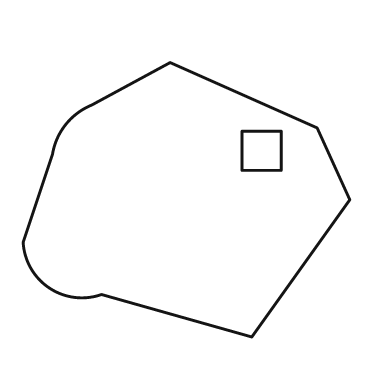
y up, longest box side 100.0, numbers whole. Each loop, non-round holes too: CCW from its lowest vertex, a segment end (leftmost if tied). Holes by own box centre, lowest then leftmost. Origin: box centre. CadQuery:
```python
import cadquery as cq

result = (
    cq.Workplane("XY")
    .moveTo(20.0, -42.0)
    .lineTo(50.0, 0.0)
    .lineTo(40.0, 22.0)
    .lineTo(-5.0, 42.0)
    .lineTo(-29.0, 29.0)
    .threePointArc((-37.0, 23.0), (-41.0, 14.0))
    .lineTo(-50.0, -13.0)
    .threePointArc((-42.0, -27.0), (-26.0, -29.0))
    .close()
    .moveTo(17.0, 9.0)
    .lineTo(29.0, 9.0)
    .lineTo(29.0, 21.0)
    .lineTo(17.0, 21.0)
    .close()
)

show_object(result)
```